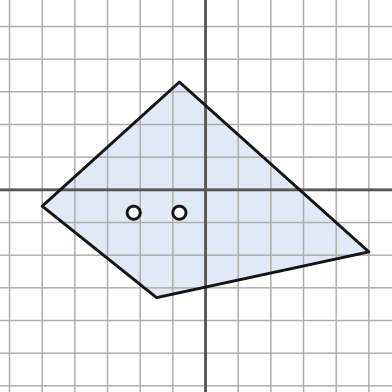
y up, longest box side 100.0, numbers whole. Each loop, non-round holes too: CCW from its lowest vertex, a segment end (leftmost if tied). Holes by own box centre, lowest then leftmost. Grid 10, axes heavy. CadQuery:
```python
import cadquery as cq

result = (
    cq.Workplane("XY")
    .moveTo(-15.0, -33.0)
    .lineTo(50.0, -19.0)
    .lineTo(-8.0, 33.0)
    .lineTo(-50.0, -5.0)
    .close()
    .moveTo(-22.0, -7.0)
    .circle(2.0)
    .moveTo(-8.0, -7.0)
    .circle(2.0)
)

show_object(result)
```